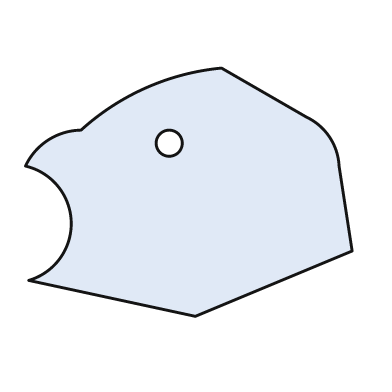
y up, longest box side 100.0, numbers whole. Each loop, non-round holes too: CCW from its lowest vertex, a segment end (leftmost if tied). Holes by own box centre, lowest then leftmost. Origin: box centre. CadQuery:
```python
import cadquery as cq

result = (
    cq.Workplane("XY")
    .moveTo(2.0, -38.0)
    .lineTo(50.0, -18.0)
    .lineTo(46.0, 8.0)
    .threePointArc((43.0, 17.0), (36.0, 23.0))
    .lineTo(10.0, 38.0)
    .threePointArc((-13.0, 32.0), (-33.0, 19.0))
    .threePointArc((-43.0, 16.0), (-50.0, 8.0))
    .threePointArc((-36.0, -9.0), (-49.0, -27.0))
    .close()
    .moveTo(-6.0, 15.0)
    .circle(4.0)
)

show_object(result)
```